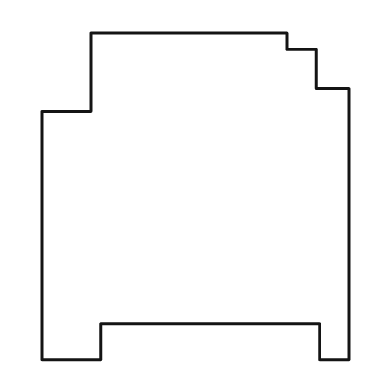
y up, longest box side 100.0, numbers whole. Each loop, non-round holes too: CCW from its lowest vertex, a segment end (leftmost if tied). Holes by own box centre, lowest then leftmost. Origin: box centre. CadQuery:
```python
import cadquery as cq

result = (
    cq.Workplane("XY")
    .moveTo(-47.0, -50.0)
    .lineTo(-29.0, -50.0)
    .lineTo(-29.0, -39.0)
    .lineTo(38.0, -39.0)
    .lineTo(38.0, -50.0)
    .lineTo(47.0, -50.0)
    .lineTo(47.0, 33.0)
    .lineTo(37.0, 33.0)
    .lineTo(37.0, 45.0)
    .lineTo(28.0, 45.0)
    .lineTo(28.0, 50.0)
    .lineTo(-32.0, 50.0)
    .lineTo(-32.0, 26.0)
    .lineTo(-47.0, 26.0)
    .close()
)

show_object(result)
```